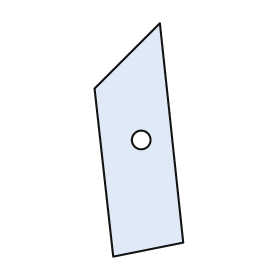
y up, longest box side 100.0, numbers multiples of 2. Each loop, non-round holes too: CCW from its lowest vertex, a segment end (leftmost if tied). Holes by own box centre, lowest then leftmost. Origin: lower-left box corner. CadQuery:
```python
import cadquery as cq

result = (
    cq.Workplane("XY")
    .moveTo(8.0, 0.0)
    .lineTo(38.0, 6.0)
    .lineTo(28.0, 100.0)
    .lineTo(0.0, 72.0)
    .close()
    .moveTo(20.0, 50.0)
    .circle(4.0)
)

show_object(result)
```